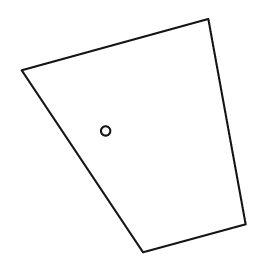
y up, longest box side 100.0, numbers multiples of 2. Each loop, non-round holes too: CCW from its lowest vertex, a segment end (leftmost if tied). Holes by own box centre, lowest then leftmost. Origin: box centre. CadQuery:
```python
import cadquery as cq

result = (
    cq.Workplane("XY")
    .moveTo(4.0, -50.0)
    .lineTo(48.0, -38.0)
    .lineTo(32.0, 50.0)
    .lineTo(-48.0, 28.0)
    .close()
    .moveTo(-12.0, 2.0)
    .circle(2.0)
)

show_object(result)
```